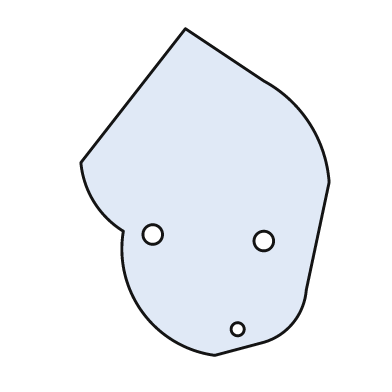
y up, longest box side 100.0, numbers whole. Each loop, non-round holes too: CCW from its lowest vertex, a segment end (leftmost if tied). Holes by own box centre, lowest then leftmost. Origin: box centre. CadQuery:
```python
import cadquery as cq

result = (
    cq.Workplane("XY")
    .moveTo(3.0, -50.0)
    .lineTo(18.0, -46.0)
    .threePointArc((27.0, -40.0), (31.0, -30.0))
    .lineTo(38.0, 3.0)
    .threePointArc((32.0, 21.0), (18.0, 34.0))
    .lineTo(-6.0, 50.0)
    .lineTo(-38.0, 9.0)
    .threePointArc((-34.0, -3.0), (-25.0, -12.0))
    .threePointArc((-19.0, -37.0), (3.0, -50.0))
    .close()
    .moveTo(10.0, -42.0)
    .circle(2.0)
    .moveTo(18.0, -15.0)
    .circle(3.0)
    .moveTo(-16.0, -13.0)
    .circle(3.0)
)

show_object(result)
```